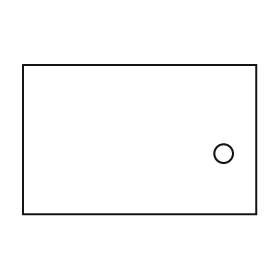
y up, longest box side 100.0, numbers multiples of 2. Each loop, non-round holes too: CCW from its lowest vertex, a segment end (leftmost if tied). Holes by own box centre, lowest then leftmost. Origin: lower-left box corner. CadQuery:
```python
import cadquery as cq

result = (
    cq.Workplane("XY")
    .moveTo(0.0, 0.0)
    .lineTo(100.0, 0.0)
    .lineTo(100.0, 64.0)
    .lineTo(0.0, 64.0)
    .close()
    .moveTo(86.0, 26.0)
    .circle(4.0)
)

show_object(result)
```